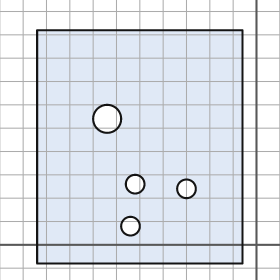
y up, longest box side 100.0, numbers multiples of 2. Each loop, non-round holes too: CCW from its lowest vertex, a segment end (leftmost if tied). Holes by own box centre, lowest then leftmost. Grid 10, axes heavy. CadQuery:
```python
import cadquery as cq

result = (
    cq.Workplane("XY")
    .moveTo(-94.0, -8.0)
    .lineTo(-6.0, -8.0)
    .lineTo(-6.0, 92.0)
    .lineTo(-94.0, 92.0)
    .close()
    .moveTo(-54.0, 8.0)
    .circle(4.0)
    .moveTo(-30.0, 24.0)
    .circle(4.0)
    .moveTo(-52.0, 26.0)
    .circle(4.0)
    .moveTo(-64.0, 54.0)
    .circle(6.0)
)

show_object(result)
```